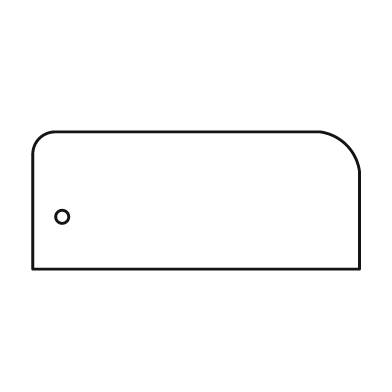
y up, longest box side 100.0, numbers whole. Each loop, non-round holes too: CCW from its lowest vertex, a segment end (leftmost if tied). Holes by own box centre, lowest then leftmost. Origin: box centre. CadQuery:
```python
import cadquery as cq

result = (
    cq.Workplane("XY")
    .moveTo(-50.0, -21.0)
    .lineTo(50.0, -21.0)
    .lineTo(50.0, 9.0)
    .threePointArc((46.0, 17.0), (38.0, 21.0))
    .lineTo(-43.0, 21.0)
    .threePointArc((-48.0, 19.0), (-50.0, 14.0))
    .close()
    .moveTo(-41.0, -5.0)
    .circle(2.0)
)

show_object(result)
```